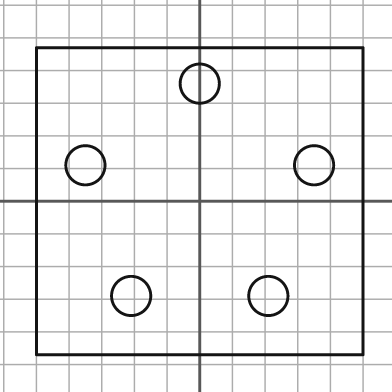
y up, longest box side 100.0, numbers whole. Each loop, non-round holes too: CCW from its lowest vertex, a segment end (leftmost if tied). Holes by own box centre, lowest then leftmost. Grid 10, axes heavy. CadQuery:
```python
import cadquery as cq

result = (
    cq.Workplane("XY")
    .moveTo(-50.0, -47.0)
    .lineTo(50.0, -47.0)
    .lineTo(50.0, 47.0)
    .lineTo(-50.0, 47.0)
    .close()
    .moveTo(-21.0, -29.0)
    .circle(6.0)
    .moveTo(21.0, -29.0)
    .circle(6.0)
    .moveTo(-35.0, 11.0)
    .circle(6.0)
    .moveTo(35.0, 11.0)
    .circle(6.0)
    .moveTo(0.0, 36.0)
    .circle(6.0)
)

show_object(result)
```